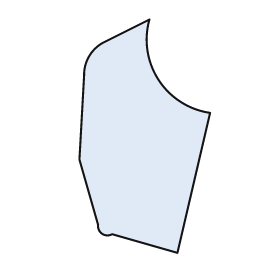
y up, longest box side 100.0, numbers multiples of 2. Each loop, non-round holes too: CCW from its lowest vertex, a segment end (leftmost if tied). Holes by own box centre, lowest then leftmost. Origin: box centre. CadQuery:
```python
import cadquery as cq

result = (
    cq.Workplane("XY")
    .moveTo(14.0, -50.0)
    .lineTo(28.0, 10.0)
    .threePointArc((6.0, 24.0), (2.0, 50.0))
    .lineTo(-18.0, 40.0)
    .threePointArc((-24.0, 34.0), (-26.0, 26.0))
    .lineTo(-28.0, -10.0)
    .lineTo(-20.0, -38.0)
    .threePointArc((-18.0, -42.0), (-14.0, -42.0))
    .close()
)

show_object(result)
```